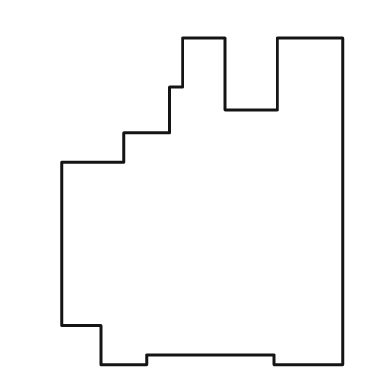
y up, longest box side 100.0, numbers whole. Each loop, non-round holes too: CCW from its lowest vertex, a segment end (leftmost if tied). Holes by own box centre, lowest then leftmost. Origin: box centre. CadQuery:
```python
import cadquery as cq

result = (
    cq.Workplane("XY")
    .moveTo(-31.0, -50.0)
    .lineTo(-17.0, -50.0)
    .lineTo(-17.0, -47.0)
    .lineTo(22.0, -47.0)
    .lineTo(22.0, -50.0)
    .lineTo(43.0, -50.0)
    .lineTo(43.0, 50.0)
    .lineTo(23.0, 50.0)
    .lineTo(23.0, 28.0)
    .lineTo(7.0, 28.0)
    .lineTo(7.0, 50.0)
    .lineTo(-6.0, 50.0)
    .lineTo(-6.0, 35.0)
    .lineTo(-10.0, 35.0)
    .lineTo(-10.0, 21.0)
    .lineTo(-24.0, 21.0)
    .lineTo(-24.0, 12.0)
    .lineTo(-43.0, 12.0)
    .lineTo(-43.0, -38.0)
    .lineTo(-31.0, -38.0)
    .close()
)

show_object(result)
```